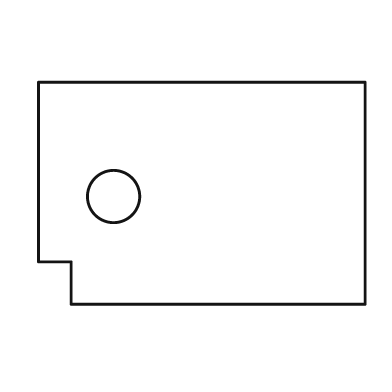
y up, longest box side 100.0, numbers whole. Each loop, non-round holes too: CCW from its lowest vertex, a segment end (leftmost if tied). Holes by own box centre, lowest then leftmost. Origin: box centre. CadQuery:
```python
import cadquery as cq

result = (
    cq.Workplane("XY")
    .moveTo(-40.0, -34.0)
    .lineTo(50.0, -34.0)
    .lineTo(50.0, 34.0)
    .lineTo(-50.0, 34.0)
    .lineTo(-50.0, -21.0)
    .lineTo(-40.0, -21.0)
    .close()
    .moveTo(-27.0, -1.0)
    .circle(8.0)
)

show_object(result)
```